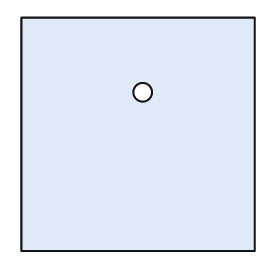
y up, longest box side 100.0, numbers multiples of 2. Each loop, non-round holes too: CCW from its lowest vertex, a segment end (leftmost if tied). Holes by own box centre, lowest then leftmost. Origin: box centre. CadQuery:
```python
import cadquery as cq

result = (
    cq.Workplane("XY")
    .moveTo(-50.0, -50.0)
    .lineTo(50.0, -50.0)
    .lineTo(50.0, 50.0)
    .lineTo(-50.0, 50.0)
    .close()
    .moveTo(2.0, 18.0)
    .circle(4.0)
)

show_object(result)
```